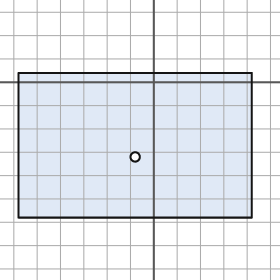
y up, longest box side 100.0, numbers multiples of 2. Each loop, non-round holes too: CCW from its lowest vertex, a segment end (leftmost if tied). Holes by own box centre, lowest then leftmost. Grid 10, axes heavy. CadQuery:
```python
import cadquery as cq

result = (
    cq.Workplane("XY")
    .moveTo(-58.0, -58.0)
    .lineTo(42.0, -58.0)
    .lineTo(42.0, 4.0)
    .lineTo(-58.0, 4.0)
    .close()
    .moveTo(-8.0, -32.0)
    .circle(2.0)
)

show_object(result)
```